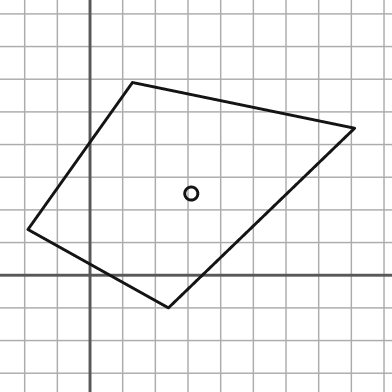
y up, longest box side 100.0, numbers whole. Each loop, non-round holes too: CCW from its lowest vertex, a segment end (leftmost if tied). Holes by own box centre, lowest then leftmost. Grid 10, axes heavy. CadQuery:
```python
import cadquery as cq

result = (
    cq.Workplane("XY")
    .moveTo(24.0, -10.0)
    .lineTo(81.0, 45.0)
    .lineTo(13.0, 59.0)
    .lineTo(-19.0, 14.0)
    .close()
    .moveTo(31.0, 25.0)
    .circle(2.0)
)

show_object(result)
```